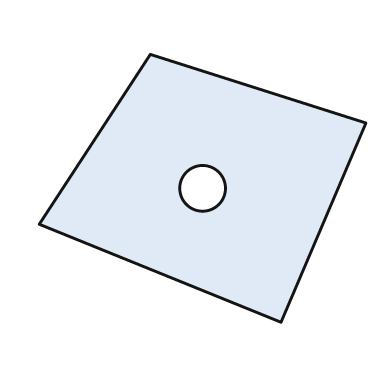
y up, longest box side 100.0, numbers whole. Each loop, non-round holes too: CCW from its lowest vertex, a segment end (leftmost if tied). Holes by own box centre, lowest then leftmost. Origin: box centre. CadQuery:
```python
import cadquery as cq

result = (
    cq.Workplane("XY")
    .moveTo(24.0, -41.0)
    .lineTo(50.0, 20.0)
    .lineTo(-16.0, 41.0)
    .lineTo(-50.0, -11.0)
    .close()
    .moveTo(0.0, 0.0)
    .circle(7.0)
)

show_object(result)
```